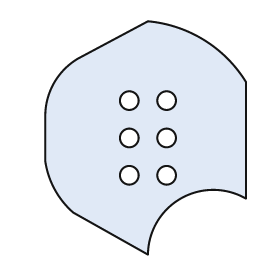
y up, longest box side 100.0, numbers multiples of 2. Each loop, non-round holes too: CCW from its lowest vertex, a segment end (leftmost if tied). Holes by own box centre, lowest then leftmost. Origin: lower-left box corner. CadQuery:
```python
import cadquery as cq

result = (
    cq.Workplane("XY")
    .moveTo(44.0, 0.0)
    .threePointArc((58.0, 24.0), (86.0, 24.0))
    .lineTo(86.0, 74.0)
    .threePointArc((68.0, 92.0), (44.0, 100.0))
    .lineTo(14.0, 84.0)
    .threePointArc((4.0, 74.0), (0.0, 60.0))
    .lineTo(0.0, 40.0)
    .threePointArc((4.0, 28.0), (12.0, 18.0))
    .close()
    .moveTo(36.0, 34.0)
    .circle(4.0)
    .moveTo(52.0, 34.0)
    .circle(4.0)
    .moveTo(36.0, 50.0)
    .circle(4.0)
    .moveTo(52.0, 50.0)
    .circle(4.0)
    .moveTo(36.0, 66.0)
    .circle(4.0)
    .moveTo(52.0, 66.0)
    .circle(4.0)
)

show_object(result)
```